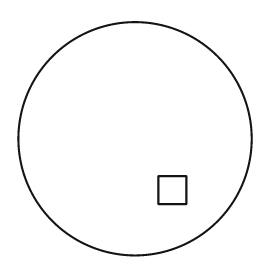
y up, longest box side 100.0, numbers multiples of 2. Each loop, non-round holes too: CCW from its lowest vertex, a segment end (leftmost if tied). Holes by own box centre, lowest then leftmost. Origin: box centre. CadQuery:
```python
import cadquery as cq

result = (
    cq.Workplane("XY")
    .moveTo(0.0, 0.0)
    .circle(50.0)
    .moveTo(10.0, -28.0)
    .lineTo(22.0, -28.0)
    .lineTo(22.0, -16.0)
    .lineTo(10.0, -16.0)
    .close()
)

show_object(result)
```